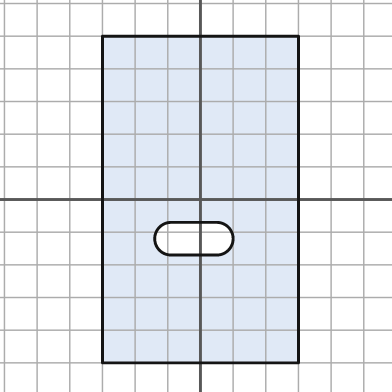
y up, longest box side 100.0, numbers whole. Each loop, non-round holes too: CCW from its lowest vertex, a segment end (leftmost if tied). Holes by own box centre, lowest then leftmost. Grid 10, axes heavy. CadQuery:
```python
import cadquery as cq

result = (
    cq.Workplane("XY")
    .moveTo(-30.0, -50.0)
    .lineTo(30.0, -50.0)
    .lineTo(30.0, 50.0)
    .lineTo(-30.0, 50.0)
    .close()
    .moveTo(-9.0, -17.0)
    .lineTo(5.0, -17.0)
    .threePointArc((10.0, -12.0), (5.0, -7.0))
    .lineTo(-9.0, -7.0)
    .threePointArc((-14.0, -12.0), (-9.0, -17.0))
    .close()
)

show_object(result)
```